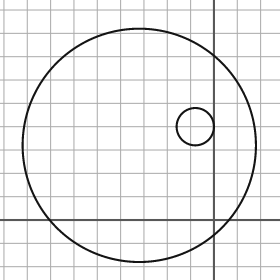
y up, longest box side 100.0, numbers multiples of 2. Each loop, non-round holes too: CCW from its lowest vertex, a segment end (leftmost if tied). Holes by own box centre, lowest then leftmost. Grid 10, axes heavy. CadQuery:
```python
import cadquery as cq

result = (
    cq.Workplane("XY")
    .moveTo(-32.0, 32.0)
    .circle(50.0)
    .moveTo(-8.0, 40.0)
    .circle(8.0)
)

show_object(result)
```